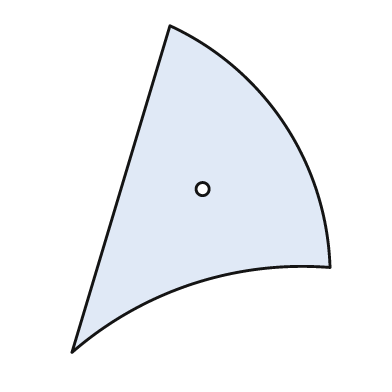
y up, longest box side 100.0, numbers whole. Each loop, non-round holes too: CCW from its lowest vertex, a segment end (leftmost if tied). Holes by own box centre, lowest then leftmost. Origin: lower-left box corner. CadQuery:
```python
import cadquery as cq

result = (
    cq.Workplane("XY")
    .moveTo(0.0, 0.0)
    .threePointArc((37.0, 21.0), (79.0, 26.0))
    .threePointArc((65.0, 70.0), (30.0, 100.0))
    .close()
    .moveTo(40.0, 50.0)
    .circle(2.0)
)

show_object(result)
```